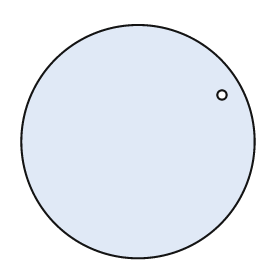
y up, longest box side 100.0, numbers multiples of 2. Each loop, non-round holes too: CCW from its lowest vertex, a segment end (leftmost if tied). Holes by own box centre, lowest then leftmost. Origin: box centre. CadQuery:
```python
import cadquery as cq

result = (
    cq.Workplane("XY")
    .moveTo(0.0, 0.0)
    .circle(50.0)
    .moveTo(36.0, 20.0)
    .circle(2.0)
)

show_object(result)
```